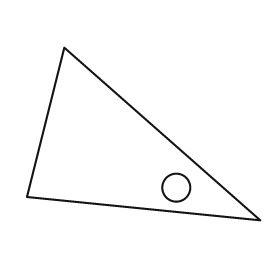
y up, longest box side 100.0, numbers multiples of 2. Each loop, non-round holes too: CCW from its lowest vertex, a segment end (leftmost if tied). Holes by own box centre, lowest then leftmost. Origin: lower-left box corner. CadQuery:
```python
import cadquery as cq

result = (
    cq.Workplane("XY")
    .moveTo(100.0, 0.0)
    .lineTo(16.0, 74.0)
    .lineTo(0.0, 10.0)
    .close()
    .moveTo(64.0, 14.0)
    .circle(6.0)
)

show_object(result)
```